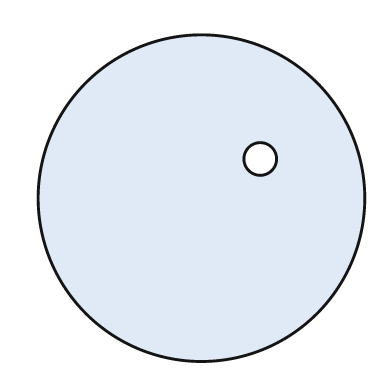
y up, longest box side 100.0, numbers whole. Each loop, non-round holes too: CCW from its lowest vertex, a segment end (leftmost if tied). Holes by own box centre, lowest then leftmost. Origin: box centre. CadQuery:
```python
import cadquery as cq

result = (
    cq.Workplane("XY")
    .moveTo(0.0, 0.0)
    .circle(50.0)
    .moveTo(18.0, 12.0)
    .circle(5.0)
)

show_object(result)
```